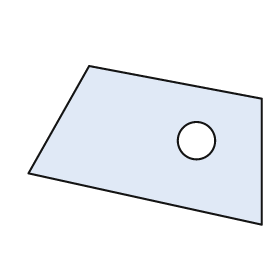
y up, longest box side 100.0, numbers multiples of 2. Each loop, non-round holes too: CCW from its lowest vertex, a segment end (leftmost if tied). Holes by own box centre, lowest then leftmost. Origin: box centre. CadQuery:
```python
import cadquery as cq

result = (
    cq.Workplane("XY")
    .moveTo(50.0, -34.0)
    .lineTo(50.0, 20.0)
    .lineTo(-24.0, 34.0)
    .lineTo(-50.0, -12.0)
    .close()
    .moveTo(22.0, 2.0)
    .circle(8.0)
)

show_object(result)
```